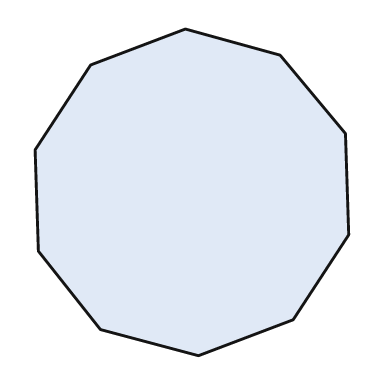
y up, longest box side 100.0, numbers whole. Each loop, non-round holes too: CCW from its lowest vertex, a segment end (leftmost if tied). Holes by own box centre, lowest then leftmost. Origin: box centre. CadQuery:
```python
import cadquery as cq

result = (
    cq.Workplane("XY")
    .moveTo(2.0, -50.0)
    .lineTo(31.0, -39.0)
    .lineTo(48.0, -13.0)
    .lineTo(47.0, 18.0)
    .lineTo(27.0, 42.0)
    .lineTo(-2.0, 50.0)
    .lineTo(-31.0, 39.0)
    .lineTo(-48.0, 13.0)
    .lineTo(-47.0, -18.0)
    .lineTo(-28.0, -42.0)
    .close()
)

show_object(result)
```